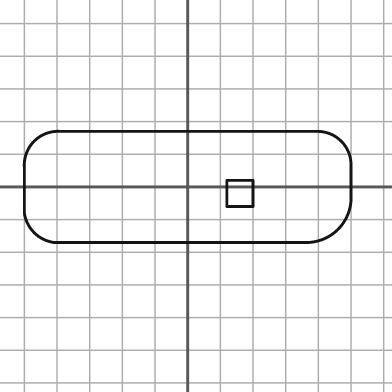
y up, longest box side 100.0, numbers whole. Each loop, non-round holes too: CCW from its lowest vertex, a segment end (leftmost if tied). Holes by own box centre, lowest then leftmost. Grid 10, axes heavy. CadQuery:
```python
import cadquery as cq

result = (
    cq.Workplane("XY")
    .moveTo(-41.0, -17.0)
    .lineTo(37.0, -17.0)
    .threePointArc((46.0, -13.0), (50.0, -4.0))
    .lineTo(50.0, 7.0)
    .threePointArc((47.0, 14.0), (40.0, 17.0))
    .lineTo(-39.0, 17.0)
    .threePointArc((-47.0, 14.0), (-50.0, 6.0))
    .lineTo(-50.0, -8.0)
    .threePointArc((-47.0, -14.0), (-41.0, -17.0))
    .close()
    .moveTo(12.0, -6.0)
    .lineTo(20.0, -6.0)
    .lineTo(20.0, 2.0)
    .lineTo(12.0, 2.0)
    .close()
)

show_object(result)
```